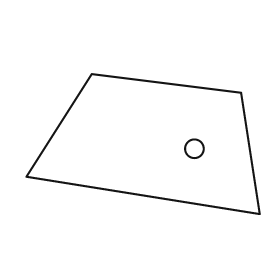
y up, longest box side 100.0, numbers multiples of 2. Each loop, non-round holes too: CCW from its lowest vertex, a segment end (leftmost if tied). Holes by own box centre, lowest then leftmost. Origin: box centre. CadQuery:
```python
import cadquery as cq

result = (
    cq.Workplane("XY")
    .moveTo(50.0, -30.0)
    .lineTo(42.0, 22.0)
    .lineTo(-22.0, 30.0)
    .lineTo(-50.0, -14.0)
    .close()
    .moveTo(22.0, -2.0)
    .circle(4.0)
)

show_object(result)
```